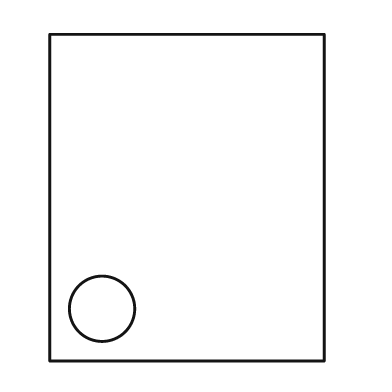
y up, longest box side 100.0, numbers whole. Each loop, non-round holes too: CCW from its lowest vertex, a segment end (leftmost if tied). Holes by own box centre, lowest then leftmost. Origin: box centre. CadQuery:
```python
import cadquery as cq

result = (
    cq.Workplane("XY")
    .moveTo(-42.0, -50.0)
    .lineTo(42.0, -50.0)
    .lineTo(42.0, 50.0)
    .lineTo(-42.0, 50.0)
    .close()
    .moveTo(-26.0, -34.0)
    .circle(10.0)
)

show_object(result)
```